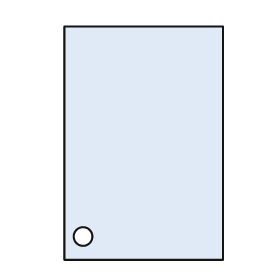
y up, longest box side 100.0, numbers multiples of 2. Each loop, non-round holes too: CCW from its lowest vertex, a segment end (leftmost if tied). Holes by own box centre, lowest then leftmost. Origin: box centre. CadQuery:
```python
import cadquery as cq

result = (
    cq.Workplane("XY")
    .moveTo(-34.0, -50.0)
    .lineTo(34.0, -50.0)
    .lineTo(34.0, 50.0)
    .lineTo(-34.0, 50.0)
    .close()
    .moveTo(-26.0, -40.0)
    .circle(4.0)
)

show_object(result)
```